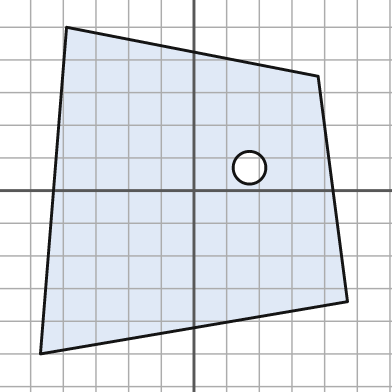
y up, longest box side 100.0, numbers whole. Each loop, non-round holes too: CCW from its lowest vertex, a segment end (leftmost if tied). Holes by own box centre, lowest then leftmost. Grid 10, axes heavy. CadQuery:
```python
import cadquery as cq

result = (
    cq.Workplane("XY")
    .moveTo(-47.0, -50.0)
    .lineTo(47.0, -34.0)
    .lineTo(38.0, 35.0)
    .lineTo(-39.0, 50.0)
    .close()
    .moveTo(17.0, 7.0)
    .circle(5.0)
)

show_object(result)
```